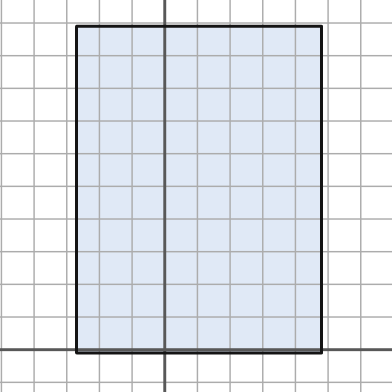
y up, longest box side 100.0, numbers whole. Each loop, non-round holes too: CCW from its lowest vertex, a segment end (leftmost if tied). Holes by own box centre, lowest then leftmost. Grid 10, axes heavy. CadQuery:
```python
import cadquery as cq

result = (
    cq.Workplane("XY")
    .moveTo(-27.0, -1.0)
    .lineTo(48.0, -1.0)
    .lineTo(48.0, 99.0)
    .lineTo(-27.0, 99.0)
    .close()
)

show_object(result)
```